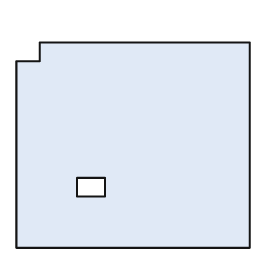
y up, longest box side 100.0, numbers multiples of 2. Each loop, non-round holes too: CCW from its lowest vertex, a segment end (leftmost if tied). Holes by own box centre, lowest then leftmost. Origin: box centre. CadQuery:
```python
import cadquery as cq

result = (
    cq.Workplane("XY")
    .moveTo(-50.0, -44.0)
    .lineTo(50.0, -44.0)
    .lineTo(50.0, 44.0)
    .lineTo(-40.0, 44.0)
    .lineTo(-40.0, 36.0)
    .lineTo(-50.0, 36.0)
    .close()
    .moveTo(-24.0, -22.0)
    .lineTo(-12.0, -22.0)
    .lineTo(-12.0, -14.0)
    .lineTo(-24.0, -14.0)
    .close()
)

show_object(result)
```